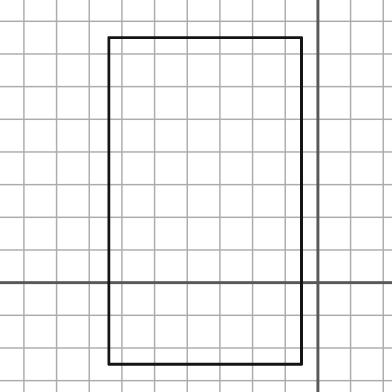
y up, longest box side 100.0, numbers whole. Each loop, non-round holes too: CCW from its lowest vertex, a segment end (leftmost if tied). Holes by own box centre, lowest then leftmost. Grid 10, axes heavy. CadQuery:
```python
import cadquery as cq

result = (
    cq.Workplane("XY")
    .moveTo(-64.0, -25.0)
    .lineTo(-5.0, -25.0)
    .lineTo(-5.0, 75.0)
    .lineTo(-64.0, 75.0)
    .close()
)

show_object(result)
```